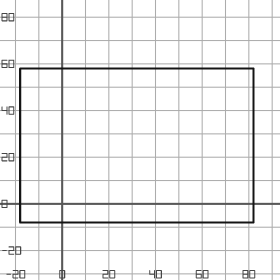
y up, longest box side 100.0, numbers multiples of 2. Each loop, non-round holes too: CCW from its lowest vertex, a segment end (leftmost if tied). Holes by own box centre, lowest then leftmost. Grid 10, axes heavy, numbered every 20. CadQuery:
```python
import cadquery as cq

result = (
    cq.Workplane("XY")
    .moveTo(-18.0, -8.0)
    .lineTo(82.0, -8.0)
    .lineTo(82.0, 58.0)
    .lineTo(-18.0, 58.0)
    .close()
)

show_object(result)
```